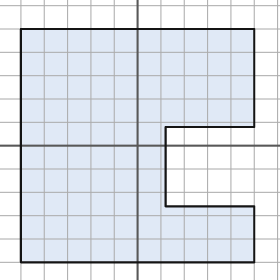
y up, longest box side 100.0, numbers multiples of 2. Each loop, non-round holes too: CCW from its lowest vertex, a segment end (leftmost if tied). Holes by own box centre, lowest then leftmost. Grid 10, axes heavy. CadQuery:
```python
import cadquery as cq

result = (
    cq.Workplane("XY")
    .moveTo(-50.0, -50.0)
    .lineTo(50.0, -50.0)
    .lineTo(50.0, -26.0)
    .lineTo(12.0, -26.0)
    .lineTo(12.0, 8.0)
    .lineTo(50.0, 8.0)
    .lineTo(50.0, 50.0)
    .lineTo(-50.0, 50.0)
    .close()
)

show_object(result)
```